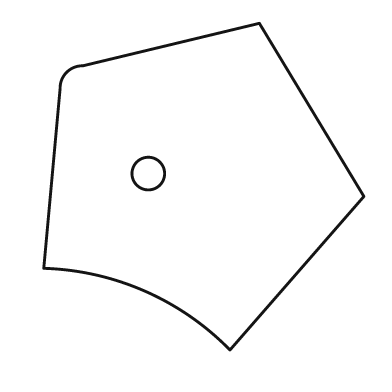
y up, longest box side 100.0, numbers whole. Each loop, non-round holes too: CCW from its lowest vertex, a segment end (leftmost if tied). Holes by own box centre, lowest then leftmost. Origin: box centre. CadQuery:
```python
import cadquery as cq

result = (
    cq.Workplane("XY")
    .moveTo(8.0, -50.0)
    .lineTo(49.0, -3.0)
    .lineTo(17.0, 50.0)
    .lineTo(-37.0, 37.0)
    .threePointArc((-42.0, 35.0), (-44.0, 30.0))
    .lineTo(-49.0, -25.0)
    .threePointArc((-18.0, -32.0), (8.0, -50.0))
    .close()
    .moveTo(-17.0, 4.0)
    .circle(5.0)
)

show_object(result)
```